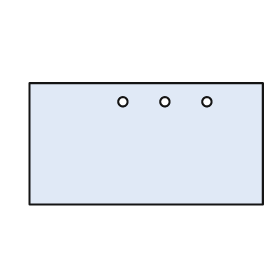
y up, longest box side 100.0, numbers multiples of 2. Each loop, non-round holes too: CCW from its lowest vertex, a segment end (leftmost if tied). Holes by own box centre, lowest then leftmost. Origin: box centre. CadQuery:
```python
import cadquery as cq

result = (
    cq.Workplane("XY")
    .moveTo(-50.0, -26.0)
    .lineTo(50.0, -26.0)
    .lineTo(50.0, 26.0)
    .lineTo(-50.0, 26.0)
    .close()
    .moveTo(-10.0, 18.0)
    .circle(2.0)
    .moveTo(8.0, 18.0)
    .circle(2.0)
    .moveTo(26.0, 18.0)
    .circle(2.0)
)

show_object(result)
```